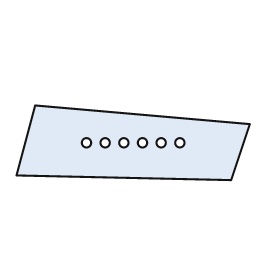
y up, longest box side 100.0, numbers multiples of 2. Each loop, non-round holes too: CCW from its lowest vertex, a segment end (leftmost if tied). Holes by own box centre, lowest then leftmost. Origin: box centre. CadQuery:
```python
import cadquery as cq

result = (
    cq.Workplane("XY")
    .moveTo(42.0, -16.0)
    .lineTo(50.0, 8.0)
    .lineTo(-42.0, 16.0)
    .lineTo(-50.0, -14.0)
    .close()
    .moveTo(-20.0, 0.0)
    .circle(2.0)
    .moveTo(-12.0, 0.0)
    .circle(2.0)
    .moveTo(-4.0, 0.0)
    .circle(2.0)
    .moveTo(4.0, 0.0)
    .circle(2.0)
    .moveTo(12.0, 0.0)
    .circle(2.0)
    .moveTo(20.0, 0.0)
    .circle(2.0)
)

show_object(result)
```